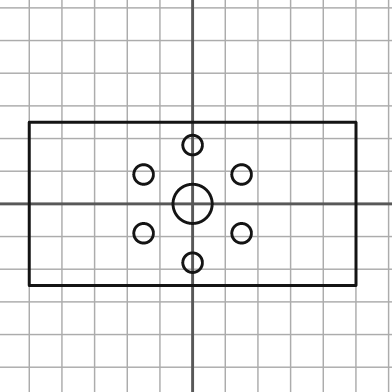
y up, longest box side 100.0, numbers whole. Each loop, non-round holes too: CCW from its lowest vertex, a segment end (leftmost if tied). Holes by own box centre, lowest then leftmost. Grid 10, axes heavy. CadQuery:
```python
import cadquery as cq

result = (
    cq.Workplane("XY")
    .moveTo(-50.0, -25.0)
    .lineTo(50.0, -25.0)
    .lineTo(50.0, 25.0)
    .lineTo(-50.0, 25.0)
    .close()
    .moveTo(0.0, -18.0)
    .circle(3.0)
    .moveTo(-15.0, -9.0)
    .circle(3.0)
    .moveTo(15.0, -9.0)
    .circle(3.0)
    .moveTo(0.0, 0.0)
    .circle(6.0)
    .moveTo(-15.0, 9.0)
    .circle(3.0)
    .moveTo(15.0, 9.0)
    .circle(3.0)
    .moveTo(0.0, 18.0)
    .circle(3.0)
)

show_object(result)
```